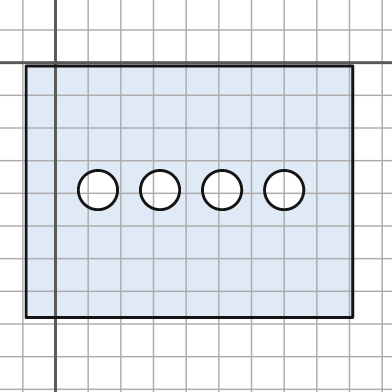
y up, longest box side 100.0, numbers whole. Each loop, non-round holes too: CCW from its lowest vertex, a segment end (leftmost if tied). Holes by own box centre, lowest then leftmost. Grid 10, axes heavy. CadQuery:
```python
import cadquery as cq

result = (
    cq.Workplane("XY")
    .moveTo(-9.0, -78.0)
    .lineTo(91.0, -78.0)
    .lineTo(91.0, -1.0)
    .lineTo(-9.0, -1.0)
    .close()
    .moveTo(13.0, -39.0)
    .circle(6.0)
    .moveTo(32.0, -39.0)
    .circle(6.0)
    .moveTo(51.0, -39.0)
    .circle(6.0)
    .moveTo(70.0, -39.0)
    .circle(6.0)
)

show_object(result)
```